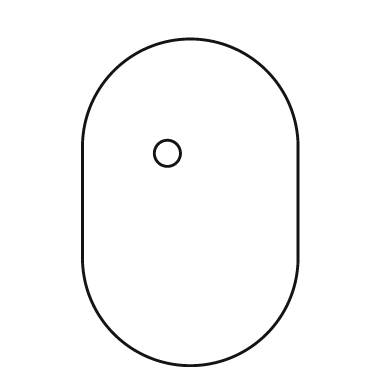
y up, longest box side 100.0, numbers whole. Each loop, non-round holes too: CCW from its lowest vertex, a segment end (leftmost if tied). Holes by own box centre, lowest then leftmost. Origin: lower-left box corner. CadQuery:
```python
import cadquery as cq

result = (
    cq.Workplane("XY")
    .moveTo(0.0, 33.0)
    .threePointArc((33.0, 0.0), (66.0, 33.0))
    .lineTo(66.0, 67.0)
    .threePointArc((33.0, 100.0), (0.0, 67.0))
    .close()
    .moveTo(26.0, 65.0)
    .circle(4.0)
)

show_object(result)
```